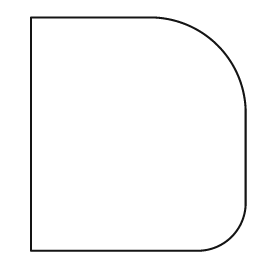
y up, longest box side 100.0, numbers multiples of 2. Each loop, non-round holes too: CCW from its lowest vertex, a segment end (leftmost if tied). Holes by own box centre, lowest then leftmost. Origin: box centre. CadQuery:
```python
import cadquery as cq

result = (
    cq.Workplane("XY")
    .moveTo(-46.0, -50.0)
    .lineTo(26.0, -50.0)
    .threePointArc((40.0, -44.0), (46.0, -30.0))
    .lineTo(46.0, 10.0)
    .threePointArc((34.0, 38.0), (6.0, 50.0))
    .lineTo(-46.0, 50.0)
    .close()
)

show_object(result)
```